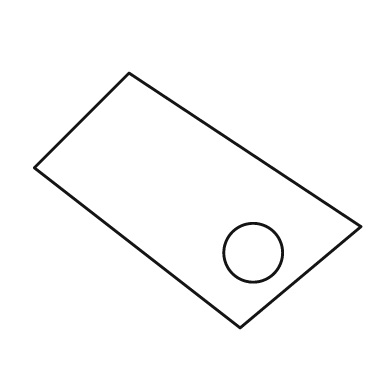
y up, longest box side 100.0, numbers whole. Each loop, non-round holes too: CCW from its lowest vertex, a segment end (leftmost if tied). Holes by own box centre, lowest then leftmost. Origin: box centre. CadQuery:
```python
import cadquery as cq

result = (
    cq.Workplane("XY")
    .moveTo(13.0, -39.0)
    .lineTo(50.0, -8.0)
    .lineTo(-21.0, 39.0)
    .lineTo(-50.0, 10.0)
    .close()
    .moveTo(17.0, -16.0)
    .circle(9.0)
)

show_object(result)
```